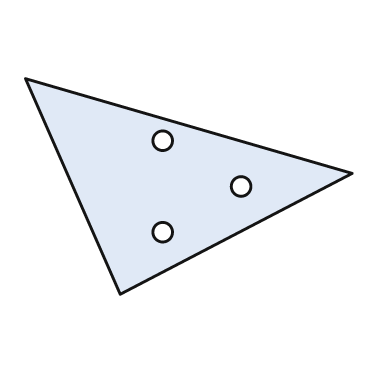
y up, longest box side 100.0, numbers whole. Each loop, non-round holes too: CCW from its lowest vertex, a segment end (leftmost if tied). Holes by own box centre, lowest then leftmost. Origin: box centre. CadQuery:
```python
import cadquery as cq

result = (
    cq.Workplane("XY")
    .moveTo(-21.0, -33.0)
    .lineTo(50.0, 4.0)
    .lineTo(-50.0, 33.0)
    .close()
    .moveTo(-8.0, -14.0)
    .circle(3.0)
    .moveTo(16.0, 0.0)
    .circle(3.0)
    .moveTo(-8.0, 14.0)
    .circle(3.0)
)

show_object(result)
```